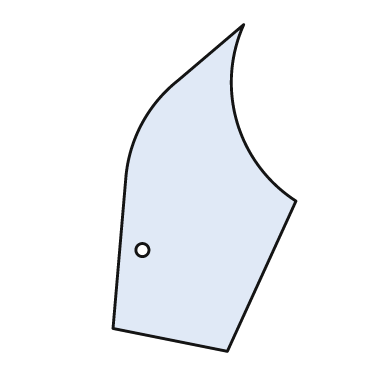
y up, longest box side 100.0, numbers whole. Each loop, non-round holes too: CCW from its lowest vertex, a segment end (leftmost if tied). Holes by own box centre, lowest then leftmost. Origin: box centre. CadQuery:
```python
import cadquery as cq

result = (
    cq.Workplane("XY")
    .moveTo(7.0, -50.0)
    .lineTo(28.0, -4.0)
    .threePointArc((10.0, 20.0), (12.0, 50.0))
    .lineTo(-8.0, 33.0)
    .threePointArc((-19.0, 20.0), (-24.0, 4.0))
    .lineTo(-28.0, -43.0)
    .close()
    .moveTo(-19.0, -19.0)
    .circle(2.0)
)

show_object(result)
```